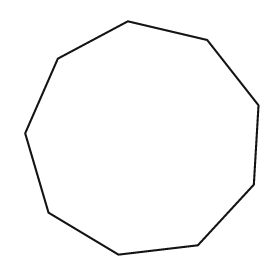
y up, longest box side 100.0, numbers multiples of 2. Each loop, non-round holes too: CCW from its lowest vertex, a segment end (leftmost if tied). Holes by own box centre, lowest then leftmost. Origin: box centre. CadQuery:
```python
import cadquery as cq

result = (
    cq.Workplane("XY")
    .moveTo(-10.0, -50.0)
    .lineTo(24.0, -46.0)
    .lineTo(48.0, -20.0)
    .lineTo(50.0, 14.0)
    .lineTo(28.0, 42.0)
    .lineTo(-6.0, 50.0)
    .lineTo(-36.0, 34.0)
    .lineTo(-50.0, 2.0)
    .lineTo(-40.0, -32.0)
    .close()
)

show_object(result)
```